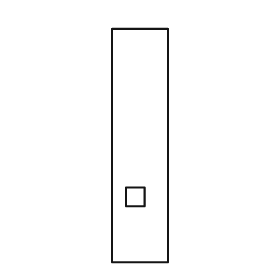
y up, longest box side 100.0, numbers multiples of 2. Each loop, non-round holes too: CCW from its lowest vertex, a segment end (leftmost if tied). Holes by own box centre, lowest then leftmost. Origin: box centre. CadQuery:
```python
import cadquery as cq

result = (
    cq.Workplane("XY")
    .moveTo(-12.0, -50.0)
    .lineTo(12.0, -50.0)
    .lineTo(12.0, 50.0)
    .lineTo(-12.0, 50.0)
    .close()
    .moveTo(-6.0, -26.0)
    .lineTo(2.0, -26.0)
    .lineTo(2.0, -18.0)
    .lineTo(-6.0, -18.0)
    .close()
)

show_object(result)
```